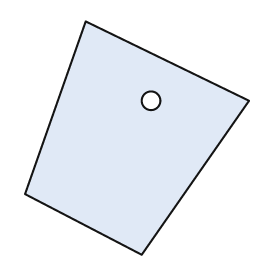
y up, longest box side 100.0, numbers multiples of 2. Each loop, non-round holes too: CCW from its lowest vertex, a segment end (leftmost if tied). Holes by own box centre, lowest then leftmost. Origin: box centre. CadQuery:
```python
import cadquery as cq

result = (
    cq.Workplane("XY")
    .moveTo(2.0, -50.0)
    .lineTo(48.0, 16.0)
    .lineTo(-22.0, 50.0)
    .lineTo(-48.0, -24.0)
    .close()
    .moveTo(6.0, 16.0)
    .circle(4.0)
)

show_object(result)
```